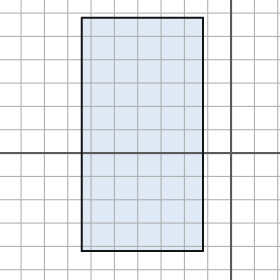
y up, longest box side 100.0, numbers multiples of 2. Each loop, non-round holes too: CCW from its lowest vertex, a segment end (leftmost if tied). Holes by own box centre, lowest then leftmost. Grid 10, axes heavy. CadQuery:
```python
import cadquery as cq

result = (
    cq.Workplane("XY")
    .moveTo(-64.0, -42.0)
    .lineTo(-12.0, -42.0)
    .lineTo(-12.0, 58.0)
    .lineTo(-64.0, 58.0)
    .close()
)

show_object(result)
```